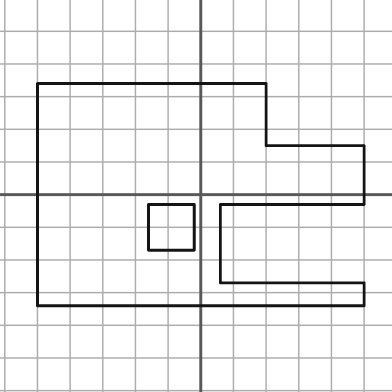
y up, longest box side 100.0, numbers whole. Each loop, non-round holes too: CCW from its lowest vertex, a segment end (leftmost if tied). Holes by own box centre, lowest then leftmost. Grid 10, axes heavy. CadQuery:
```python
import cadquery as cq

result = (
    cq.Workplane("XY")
    .moveTo(-50.0, -34.0)
    .lineTo(50.0, -34.0)
    .lineTo(50.0, -27.0)
    .lineTo(6.0, -27.0)
    .lineTo(6.0, -3.0)
    .lineTo(50.0, -3.0)
    .lineTo(50.0, 15.0)
    .lineTo(20.0, 15.0)
    .lineTo(20.0, 34.0)
    .lineTo(-50.0, 34.0)
    .close()
    .moveTo(-16.0, -17.0)
    .lineTo(-2.0, -17.0)
    .lineTo(-2.0, -3.0)
    .lineTo(-16.0, -3.0)
    .close()
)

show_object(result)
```